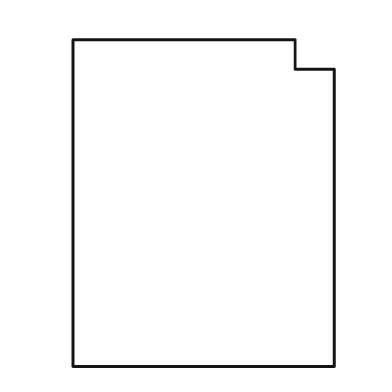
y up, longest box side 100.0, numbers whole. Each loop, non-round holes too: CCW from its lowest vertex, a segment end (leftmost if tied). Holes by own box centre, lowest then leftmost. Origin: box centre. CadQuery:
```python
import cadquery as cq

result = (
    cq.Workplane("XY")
    .moveTo(-40.0, -50.0)
    .lineTo(40.0, -50.0)
    .lineTo(40.0, 41.0)
    .lineTo(28.0, 41.0)
    .lineTo(28.0, 50.0)
    .lineTo(-40.0, 50.0)
    .close()
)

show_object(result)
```